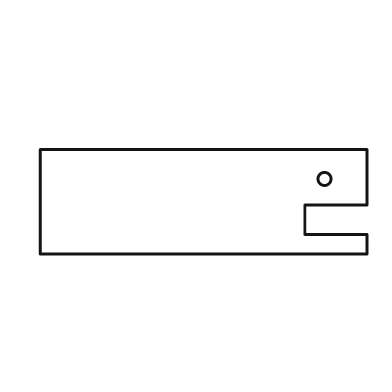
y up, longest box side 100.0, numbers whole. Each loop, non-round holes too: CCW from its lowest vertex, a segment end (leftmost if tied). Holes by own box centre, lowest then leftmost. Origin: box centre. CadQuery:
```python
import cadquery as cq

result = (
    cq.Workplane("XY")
    .moveTo(-50.0, -16.0)
    .lineTo(50.0, -16.0)
    .lineTo(50.0, -10.0)
    .lineTo(31.0, -10.0)
    .lineTo(31.0, -1.0)
    .lineTo(50.0, -1.0)
    .lineTo(50.0, 16.0)
    .lineTo(-50.0, 16.0)
    .close()
    .moveTo(37.0, 7.0)
    .circle(2.0)
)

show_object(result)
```